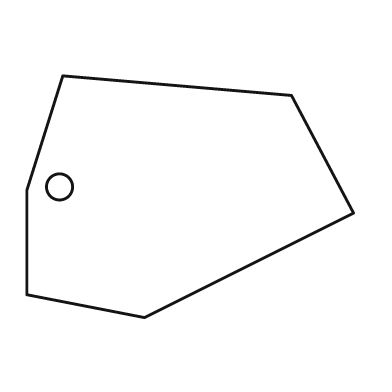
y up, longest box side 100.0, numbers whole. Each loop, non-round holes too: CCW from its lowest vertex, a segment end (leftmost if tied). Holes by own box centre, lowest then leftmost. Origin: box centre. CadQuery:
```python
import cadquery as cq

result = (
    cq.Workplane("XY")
    .moveTo(-14.0, -37.0)
    .lineTo(50.0, -5.0)
    .lineTo(31.0, 31.0)
    .lineTo(-39.0, 37.0)
    .lineTo(-50.0, 2.0)
    .lineTo(-50.0, -30.0)
    .close()
    .moveTo(-40.0, 3.0)
    .circle(4.0)
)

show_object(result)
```